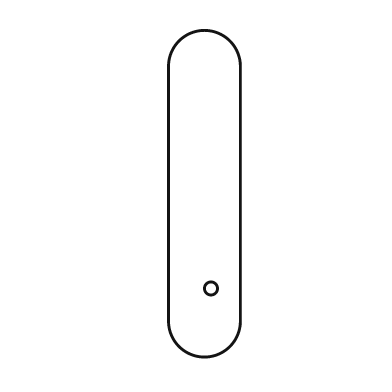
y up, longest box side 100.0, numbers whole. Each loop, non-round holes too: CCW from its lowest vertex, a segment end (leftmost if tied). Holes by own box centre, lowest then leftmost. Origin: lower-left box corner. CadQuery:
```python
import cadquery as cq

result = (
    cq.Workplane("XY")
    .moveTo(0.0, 11.0)
    .threePointArc((11.0, 0.0), (22.0, 11.0))
    .lineTo(22.0, 89.0)
    .threePointArc((11.0, 100.0), (0.0, 89.0))
    .close()
    .moveTo(13.0, 21.0)
    .circle(2.0)
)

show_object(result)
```